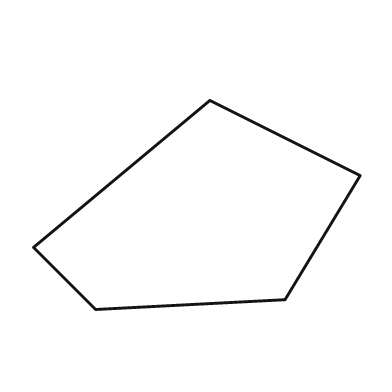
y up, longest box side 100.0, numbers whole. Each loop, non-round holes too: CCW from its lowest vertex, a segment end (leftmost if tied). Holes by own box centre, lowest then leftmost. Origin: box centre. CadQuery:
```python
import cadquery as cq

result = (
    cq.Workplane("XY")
    .moveTo(-31.0, -32.0)
    .lineTo(27.0, -29.0)
    .lineTo(50.0, 9.0)
    .lineTo(4.0, 32.0)
    .lineTo(-50.0, -13.0)
    .close()
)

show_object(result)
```